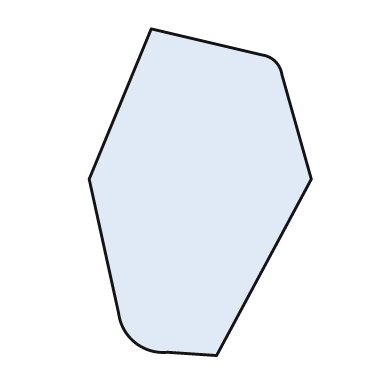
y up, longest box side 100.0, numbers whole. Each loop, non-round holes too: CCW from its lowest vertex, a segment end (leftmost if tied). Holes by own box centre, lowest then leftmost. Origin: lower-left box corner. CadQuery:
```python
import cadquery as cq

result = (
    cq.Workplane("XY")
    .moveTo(39.0, 0.0)
    .lineTo(68.0, 54.0)
    .lineTo(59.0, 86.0)
    .threePointArc((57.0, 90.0), (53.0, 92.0))
    .lineTo(19.0, 100.0)
    .lineTo(0.0, 54.0)
    .lineTo(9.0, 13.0)
    .threePointArc((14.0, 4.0), (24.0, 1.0))
    .close()
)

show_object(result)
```